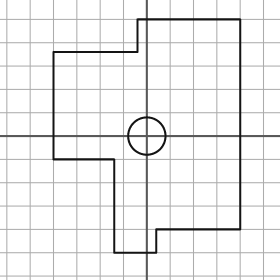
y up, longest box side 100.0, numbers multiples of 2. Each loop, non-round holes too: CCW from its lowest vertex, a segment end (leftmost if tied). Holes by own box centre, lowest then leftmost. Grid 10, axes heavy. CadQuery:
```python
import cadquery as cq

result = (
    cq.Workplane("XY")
    .moveTo(-14.0, -50.0)
    .lineTo(4.0, -50.0)
    .lineTo(4.0, -40.0)
    .lineTo(40.0, -40.0)
    .lineTo(40.0, 50.0)
    .lineTo(-4.0, 50.0)
    .lineTo(-4.0, 36.0)
    .lineTo(-40.0, 36.0)
    .lineTo(-40.0, -10.0)
    .lineTo(-14.0, -10.0)
    .close()
    .moveTo(0.0, 0.0)
    .circle(8.0)
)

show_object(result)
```